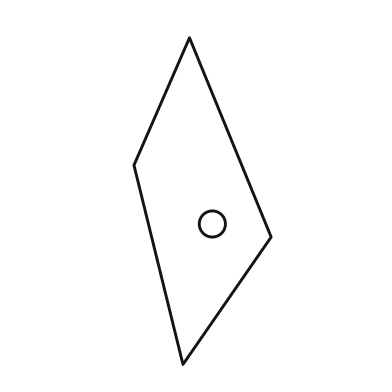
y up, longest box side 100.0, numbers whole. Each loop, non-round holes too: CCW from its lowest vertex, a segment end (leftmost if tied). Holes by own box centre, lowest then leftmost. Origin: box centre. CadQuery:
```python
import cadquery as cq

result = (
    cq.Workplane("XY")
    .moveTo(-6.0, -50.0)
    .lineTo(21.0, -11.0)
    .lineTo(-4.0, 50.0)
    .lineTo(-21.0, 11.0)
    .close()
    .moveTo(3.0, -7.0)
    .circle(4.0)
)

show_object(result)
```